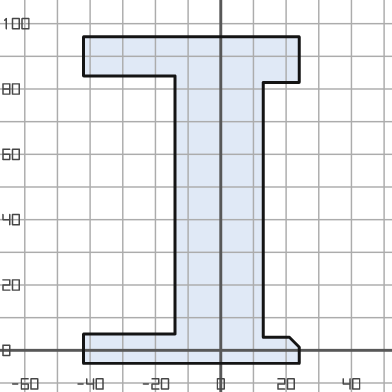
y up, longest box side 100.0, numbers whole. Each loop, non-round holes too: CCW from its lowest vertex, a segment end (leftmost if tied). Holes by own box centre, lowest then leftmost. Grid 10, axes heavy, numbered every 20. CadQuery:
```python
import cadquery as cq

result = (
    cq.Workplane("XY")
    .moveTo(-42.0, -4.0)
    .lineTo(24.0, -4.0)
    .lineTo(24.0, 1.0)
    .lineTo(21.0, 4.0)
    .lineTo(13.0, 4.0)
    .lineTo(13.0, 82.0)
    .lineTo(24.0, 82.0)
    .lineTo(24.0, 96.0)
    .lineTo(-42.0, 96.0)
    .lineTo(-42.0, 84.0)
    .lineTo(-14.0, 84.0)
    .lineTo(-14.0, 5.0)
    .lineTo(-42.0, 5.0)
    .close()
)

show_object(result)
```